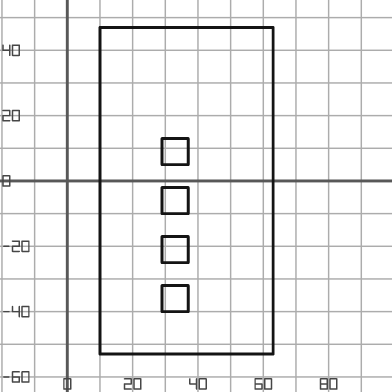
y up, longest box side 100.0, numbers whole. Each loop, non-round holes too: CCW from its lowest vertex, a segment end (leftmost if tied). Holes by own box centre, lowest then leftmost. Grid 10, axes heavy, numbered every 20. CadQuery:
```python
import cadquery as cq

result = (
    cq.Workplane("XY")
    .moveTo(10.0, -53.0)
    .lineTo(63.0, -53.0)
    .lineTo(63.0, 47.0)
    .lineTo(10.0, 47.0)
    .close()
    .moveTo(29.0, -40.0)
    .lineTo(37.0, -40.0)
    .lineTo(37.0, -32.0)
    .lineTo(29.0, -32.0)
    .close()
    .moveTo(29.0, -25.0)
    .lineTo(37.0, -25.0)
    .lineTo(37.0, -17.0)
    .lineTo(29.0, -17.0)
    .close()
    .moveTo(29.0, -10.0)
    .lineTo(37.0, -10.0)
    .lineTo(37.0, -2.0)
    .lineTo(29.0, -2.0)
    .close()
    .moveTo(29.0, 5.0)
    .lineTo(37.0, 5.0)
    .lineTo(37.0, 13.0)
    .lineTo(29.0, 13.0)
    .close()
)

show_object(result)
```